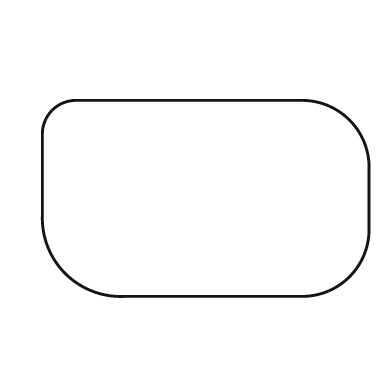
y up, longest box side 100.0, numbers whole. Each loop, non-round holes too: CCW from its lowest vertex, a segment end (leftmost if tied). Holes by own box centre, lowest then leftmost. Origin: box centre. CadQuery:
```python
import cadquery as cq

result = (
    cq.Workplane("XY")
    .moveTo(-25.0, -30.0)
    .lineTo(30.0, -30.0)
    .threePointArc((44.0, -24.0), (50.0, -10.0))
    .lineTo(50.0, 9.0)
    .threePointArc((44.0, 24.0), (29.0, 30.0))
    .lineTo(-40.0, 30.0)
    .threePointArc((-47.0, 27.0), (-50.0, 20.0))
    .lineTo(-50.0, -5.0)
    .threePointArc((-43.0, -23.0), (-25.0, -30.0))
    .close()
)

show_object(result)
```